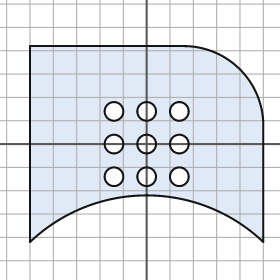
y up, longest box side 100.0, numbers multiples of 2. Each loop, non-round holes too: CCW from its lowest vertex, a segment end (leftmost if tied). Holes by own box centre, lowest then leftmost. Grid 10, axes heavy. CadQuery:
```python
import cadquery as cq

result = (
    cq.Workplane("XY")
    .moveTo(-50.0, -42.0)
    .threePointArc((0.0, -22.0), (50.0, -42.0))
    .lineTo(50.0, 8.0)
    .threePointArc((40.0, 32.0), (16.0, 42.0))
    .lineTo(-50.0, 42.0)
    .close()
    .moveTo(-14.0, -14.0)
    .circle(4.0)
    .moveTo(0.0, -14.0)
    .circle(4.0)
    .moveTo(14.0, -14.0)
    .circle(4.0)
    .moveTo(-14.0, 0.0)
    .circle(4.0)
    .moveTo(0.0, 0.0)
    .circle(4.0)
    .moveTo(14.0, 0.0)
    .circle(4.0)
    .moveTo(-14.0, 14.0)
    .circle(4.0)
    .moveTo(0.0, 14.0)
    .circle(4.0)
    .moveTo(14.0, 14.0)
    .circle(4.0)
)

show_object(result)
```